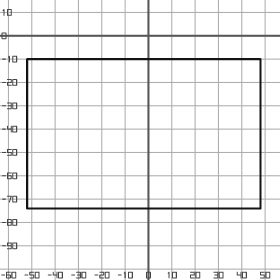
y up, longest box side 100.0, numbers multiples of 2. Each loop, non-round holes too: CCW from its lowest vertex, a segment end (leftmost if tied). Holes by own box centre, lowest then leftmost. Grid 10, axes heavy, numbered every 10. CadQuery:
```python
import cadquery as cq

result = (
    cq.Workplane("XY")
    .moveTo(-52.0, -74.0)
    .lineTo(48.0, -74.0)
    .lineTo(48.0, -10.0)
    .lineTo(-52.0, -10.0)
    .close()
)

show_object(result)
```